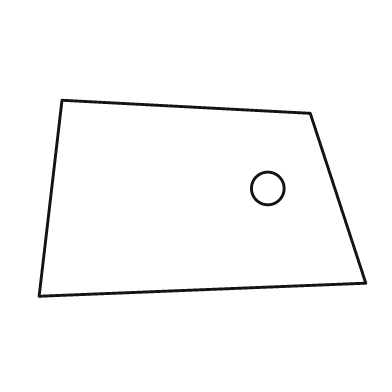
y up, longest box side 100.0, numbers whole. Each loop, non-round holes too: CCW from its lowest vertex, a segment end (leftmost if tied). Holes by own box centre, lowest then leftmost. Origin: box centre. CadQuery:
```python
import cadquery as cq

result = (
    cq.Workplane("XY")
    .moveTo(-50.0, -30.0)
    .lineTo(50.0, -26.0)
    .lineTo(33.0, 26.0)
    .lineTo(-43.0, 30.0)
    .close()
    .moveTo(20.0, 3.0)
    .circle(5.0)
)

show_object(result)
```